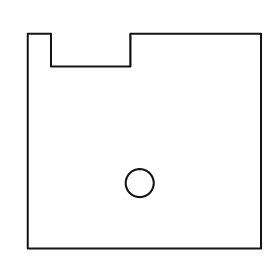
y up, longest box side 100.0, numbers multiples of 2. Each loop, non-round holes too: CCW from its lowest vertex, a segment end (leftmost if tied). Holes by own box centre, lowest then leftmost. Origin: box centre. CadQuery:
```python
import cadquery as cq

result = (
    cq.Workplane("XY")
    .moveTo(-50.0, -46.0)
    .lineTo(50.0, -46.0)
    .lineTo(50.0, 46.0)
    .lineTo(-6.0, 46.0)
    .lineTo(-6.0, 32.0)
    .lineTo(-40.0, 32.0)
    .lineTo(-40.0, 46.0)
    .lineTo(-50.0, 46.0)
    .close()
    .moveTo(-2.0, -18.0)
    .circle(6.0)
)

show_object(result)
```